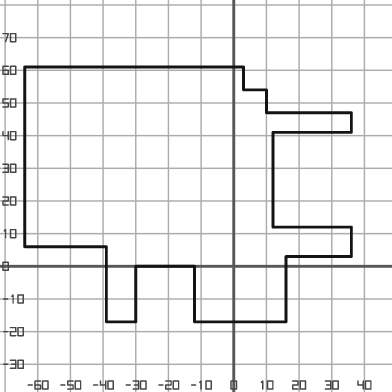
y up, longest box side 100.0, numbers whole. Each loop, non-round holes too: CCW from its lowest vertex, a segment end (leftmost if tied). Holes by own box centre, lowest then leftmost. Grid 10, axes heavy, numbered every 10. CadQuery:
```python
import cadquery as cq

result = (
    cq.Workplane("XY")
    .moveTo(-39.0, -17.0)
    .lineTo(-30.0, -17.0)
    .lineTo(-30.0, 0.0)
    .lineTo(-12.0, 0.0)
    .lineTo(-12.0, -17.0)
    .lineTo(16.0, -17.0)
    .lineTo(16.0, 3.0)
    .lineTo(36.0, 3.0)
    .lineTo(36.0, 12.0)
    .lineTo(12.0, 12.0)
    .lineTo(12.0, 41.0)
    .lineTo(36.0, 41.0)
    .lineTo(36.0, 47.0)
    .lineTo(10.0, 47.0)
    .lineTo(10.0, 54.0)
    .lineTo(3.0, 54.0)
    .lineTo(3.0, 61.0)
    .lineTo(-64.0, 61.0)
    .lineTo(-64.0, 6.0)
    .lineTo(-39.0, 6.0)
    .close()
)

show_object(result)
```